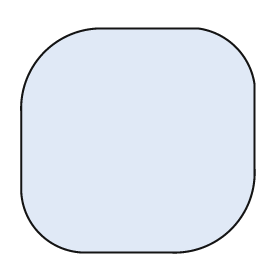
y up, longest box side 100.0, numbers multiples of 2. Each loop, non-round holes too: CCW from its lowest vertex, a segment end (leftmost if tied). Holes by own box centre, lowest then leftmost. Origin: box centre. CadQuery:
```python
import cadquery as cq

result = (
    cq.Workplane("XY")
    .moveTo(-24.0, -48.0)
    .lineTo(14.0, -48.0)
    .threePointArc((40.0, -38.0), (50.0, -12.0))
    .lineTo(50.0, 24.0)
    .threePointArc((42.0, 40.0), (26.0, 48.0))
    .lineTo(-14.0, 48.0)
    .threePointArc((-40.0, 38.0), (-50.0, 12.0))
    .lineTo(-50.0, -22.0)
    .threePointArc((-42.0, -40.0), (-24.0, -48.0))
    .close()
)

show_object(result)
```